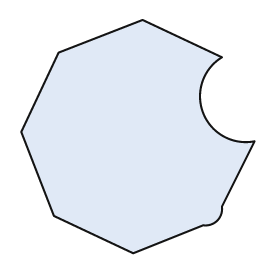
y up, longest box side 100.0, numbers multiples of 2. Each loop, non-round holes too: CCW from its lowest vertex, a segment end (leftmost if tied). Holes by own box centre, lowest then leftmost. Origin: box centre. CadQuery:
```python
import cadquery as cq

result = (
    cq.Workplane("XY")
    .moveTo(-2.0, -50.0)
    .lineTo(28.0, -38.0)
    .threePointArc((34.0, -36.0), (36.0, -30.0))
    .lineTo(50.0, -2.0)
    .threePointArc((28.0, 10.0), (36.0, 34.0))
    .lineTo(2.0, 50.0)
    .lineTo(-34.0, 36.0)
    .lineTo(-50.0, 2.0)
    .lineTo(-36.0, -34.0)
    .close()
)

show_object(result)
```